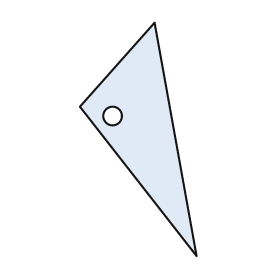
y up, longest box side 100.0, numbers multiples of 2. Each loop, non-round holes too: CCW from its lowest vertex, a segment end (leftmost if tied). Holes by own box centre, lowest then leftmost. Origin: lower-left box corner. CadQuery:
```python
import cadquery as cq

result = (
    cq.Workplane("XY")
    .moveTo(50.0, 0.0)
    .lineTo(32.0, 100.0)
    .lineTo(0.0, 64.0)
    .close()
    .moveTo(14.0, 60.0)
    .circle(4.0)
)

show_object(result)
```